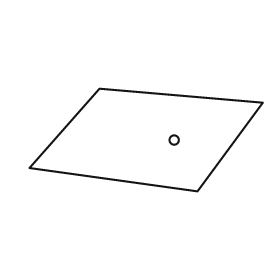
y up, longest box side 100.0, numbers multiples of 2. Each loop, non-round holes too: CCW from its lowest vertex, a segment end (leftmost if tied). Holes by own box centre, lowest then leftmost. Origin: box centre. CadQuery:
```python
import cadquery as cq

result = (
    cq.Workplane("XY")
    .moveTo(22.0, -22.0)
    .lineTo(50.0, 16.0)
    .lineTo(-20.0, 22.0)
    .lineTo(-50.0, -12.0)
    .close()
    .moveTo(12.0, 0.0)
    .circle(2.0)
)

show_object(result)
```